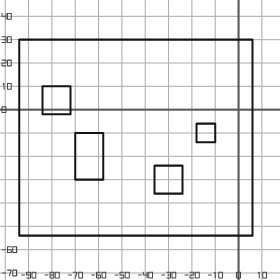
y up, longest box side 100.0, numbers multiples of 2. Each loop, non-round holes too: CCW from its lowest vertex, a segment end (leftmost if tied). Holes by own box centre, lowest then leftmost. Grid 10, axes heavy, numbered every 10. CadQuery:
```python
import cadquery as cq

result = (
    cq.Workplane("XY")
    .moveTo(-94.0, -54.0)
    .lineTo(6.0, -54.0)
    .lineTo(6.0, 30.0)
    .lineTo(-94.0, 30.0)
    .close()
    .moveTo(-36.0, -36.0)
    .lineTo(-24.0, -36.0)
    .lineTo(-24.0, -24.0)
    .lineTo(-36.0, -24.0)
    .close()
    .moveTo(-70.0, -30.0)
    .lineTo(-58.0, -30.0)
    .lineTo(-58.0, -10.0)
    .lineTo(-70.0, -10.0)
    .close()
    .moveTo(-18.0, -14.0)
    .lineTo(-10.0, -14.0)
    .lineTo(-10.0, -6.0)
    .lineTo(-18.0, -6.0)
    .close()
    .moveTo(-84.0, -2.0)
    .lineTo(-72.0, -2.0)
    .lineTo(-72.0, 10.0)
    .lineTo(-84.0, 10.0)
    .close()
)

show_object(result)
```